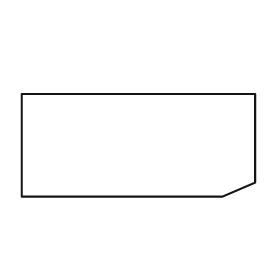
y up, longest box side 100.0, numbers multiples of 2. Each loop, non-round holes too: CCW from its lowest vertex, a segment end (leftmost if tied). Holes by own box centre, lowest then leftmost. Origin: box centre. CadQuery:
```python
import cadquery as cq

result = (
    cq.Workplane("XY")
    .moveTo(-50.0, -22.0)
    .lineTo(36.0, -22.0)
    .lineTo(50.0, -16.0)
    .lineTo(50.0, 22.0)
    .lineTo(-50.0, 22.0)
    .close()
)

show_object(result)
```